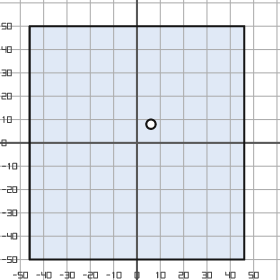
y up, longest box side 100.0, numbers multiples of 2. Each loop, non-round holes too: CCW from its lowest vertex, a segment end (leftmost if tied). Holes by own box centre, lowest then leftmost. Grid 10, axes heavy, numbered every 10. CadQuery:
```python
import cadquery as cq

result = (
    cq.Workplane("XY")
    .moveTo(-46.0, -50.0)
    .lineTo(46.0, -50.0)
    .lineTo(46.0, 50.0)
    .lineTo(-46.0, 50.0)
    .close()
    .moveTo(6.0, 8.0)
    .circle(2.0)
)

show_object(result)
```